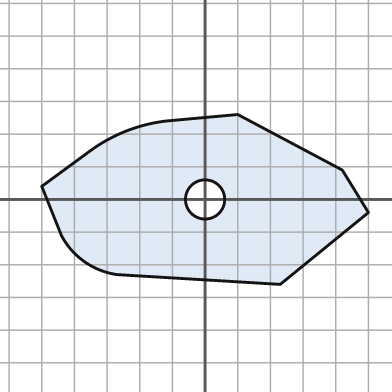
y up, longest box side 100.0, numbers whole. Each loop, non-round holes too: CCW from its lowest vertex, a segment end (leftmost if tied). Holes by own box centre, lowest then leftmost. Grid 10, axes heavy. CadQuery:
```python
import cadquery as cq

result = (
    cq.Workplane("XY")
    .moveTo(23.0, -26.0)
    .lineTo(50.0, -4.0)
    .lineTo(42.0, 9.0)
    .lineTo(10.0, 26.0)
    .lineTo(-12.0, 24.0)
    .threePointArc((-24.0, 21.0), (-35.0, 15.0))
    .lineTo(-50.0, 4.0)
    .lineTo(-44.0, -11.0)
    .threePointArc((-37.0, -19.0), (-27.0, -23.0))
    .close()
    .moveTo(0.0, 0.0)
    .circle(6.0)
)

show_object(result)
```